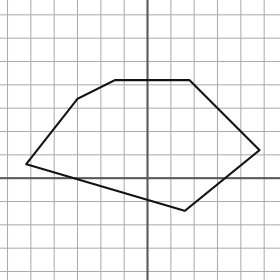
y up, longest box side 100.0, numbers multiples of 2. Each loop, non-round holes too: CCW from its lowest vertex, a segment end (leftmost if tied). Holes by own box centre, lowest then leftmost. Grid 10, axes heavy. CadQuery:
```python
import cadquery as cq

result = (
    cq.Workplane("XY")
    .moveTo(16.0, -14.0)
    .lineTo(48.0, 12.0)
    .lineTo(18.0, 42.0)
    .lineTo(-14.0, 42.0)
    .lineTo(-30.0, 34.0)
    .lineTo(-52.0, 6.0)
    .close()
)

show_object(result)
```